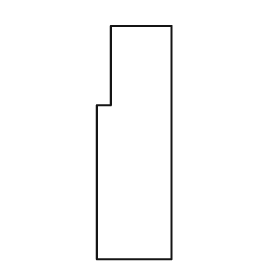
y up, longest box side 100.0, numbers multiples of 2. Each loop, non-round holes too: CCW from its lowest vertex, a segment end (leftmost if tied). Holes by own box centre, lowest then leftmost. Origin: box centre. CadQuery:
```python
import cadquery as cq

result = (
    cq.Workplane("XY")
    .moveTo(-16.0, -50.0)
    .lineTo(16.0, -50.0)
    .lineTo(16.0, 50.0)
    .lineTo(-10.0, 50.0)
    .lineTo(-10.0, 16.0)
    .lineTo(-16.0, 16.0)
    .close()
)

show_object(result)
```